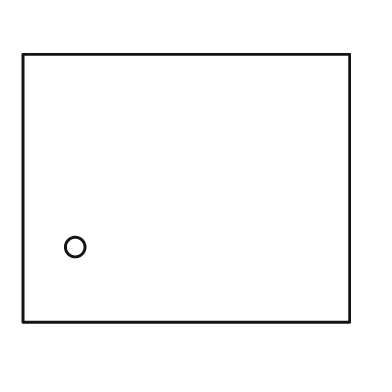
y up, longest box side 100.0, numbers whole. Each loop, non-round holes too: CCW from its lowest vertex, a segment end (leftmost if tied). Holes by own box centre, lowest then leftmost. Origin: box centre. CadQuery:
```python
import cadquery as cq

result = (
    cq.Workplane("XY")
    .moveTo(-50.0, -41.0)
    .lineTo(50.0, -41.0)
    .lineTo(50.0, 41.0)
    .lineTo(-50.0, 41.0)
    .close()
    .moveTo(-34.0, -18.0)
    .circle(3.0)
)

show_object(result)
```